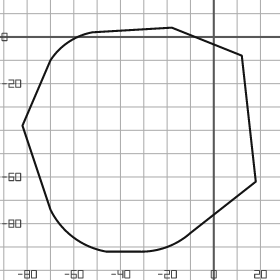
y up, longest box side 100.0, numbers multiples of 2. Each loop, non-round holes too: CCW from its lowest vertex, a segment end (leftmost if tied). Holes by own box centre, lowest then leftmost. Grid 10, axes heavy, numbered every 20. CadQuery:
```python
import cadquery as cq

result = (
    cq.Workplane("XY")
    .moveTo(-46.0, -92.0)
    .lineTo(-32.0, -92.0)
    .threePointArc((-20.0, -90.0), (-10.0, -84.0))
    .lineTo(18.0, -62.0)
    .lineTo(12.0, -8.0)
    .lineTo(-18.0, 4.0)
    .lineTo(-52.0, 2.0)
    .threePointArc((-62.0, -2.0), (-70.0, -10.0))
    .lineTo(-82.0, -38.0)
    .lineTo(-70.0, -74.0)
    .threePointArc((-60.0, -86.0), (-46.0, -92.0))
    .close()
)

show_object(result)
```